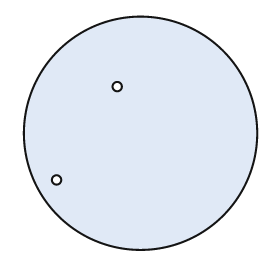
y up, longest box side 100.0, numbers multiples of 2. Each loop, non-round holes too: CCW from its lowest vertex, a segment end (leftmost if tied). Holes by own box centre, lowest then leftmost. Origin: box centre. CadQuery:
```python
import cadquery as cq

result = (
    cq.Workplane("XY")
    .moveTo(0.0, 0.0)
    .circle(50.0)
    .moveTo(-36.0, -20.0)
    .circle(2.0)
    .moveTo(-10.0, 20.0)
    .circle(2.0)
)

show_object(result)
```